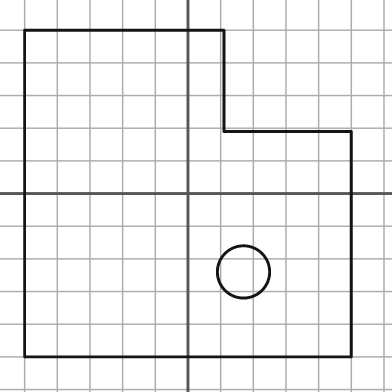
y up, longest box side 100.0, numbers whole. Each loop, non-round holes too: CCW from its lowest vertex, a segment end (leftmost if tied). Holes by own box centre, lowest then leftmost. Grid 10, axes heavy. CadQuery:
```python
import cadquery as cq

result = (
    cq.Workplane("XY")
    .moveTo(-50.0, -50.0)
    .lineTo(50.0, -50.0)
    .lineTo(50.0, 19.0)
    .lineTo(11.0, 19.0)
    .lineTo(11.0, 50.0)
    .lineTo(-50.0, 50.0)
    .close()
    .moveTo(17.0, -24.0)
    .circle(8.0)
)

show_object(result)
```